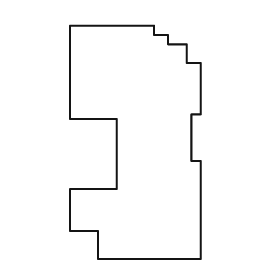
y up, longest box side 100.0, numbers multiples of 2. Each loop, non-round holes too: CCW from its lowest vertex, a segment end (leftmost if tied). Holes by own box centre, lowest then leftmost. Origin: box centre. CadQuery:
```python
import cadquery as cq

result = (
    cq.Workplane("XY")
    .moveTo(-16.0, -50.0)
    .lineTo(28.0, -50.0)
    .lineTo(28.0, -8.0)
    .lineTo(24.0, -8.0)
    .lineTo(24.0, 12.0)
    .lineTo(28.0, 12.0)
    .lineTo(28.0, 34.0)
    .lineTo(22.0, 34.0)
    .lineTo(22.0, 42.0)
    .lineTo(14.0, 42.0)
    .lineTo(14.0, 46.0)
    .lineTo(8.0, 46.0)
    .lineTo(8.0, 50.0)
    .lineTo(-28.0, 50.0)
    .lineTo(-28.0, 10.0)
    .lineTo(-8.0, 10.0)
    .lineTo(-8.0, -20.0)
    .lineTo(-28.0, -20.0)
    .lineTo(-28.0, -38.0)
    .lineTo(-16.0, -38.0)
    .close()
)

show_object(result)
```